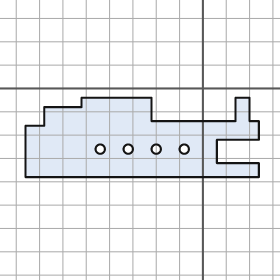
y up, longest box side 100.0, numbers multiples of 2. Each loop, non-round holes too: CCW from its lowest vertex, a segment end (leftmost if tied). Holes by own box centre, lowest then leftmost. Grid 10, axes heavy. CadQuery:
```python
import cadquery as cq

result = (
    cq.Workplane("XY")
    .moveTo(-76.0, -38.0)
    .lineTo(24.0, -38.0)
    .lineTo(24.0, -32.0)
    .lineTo(6.0, -32.0)
    .lineTo(6.0, -22.0)
    .lineTo(24.0, -22.0)
    .lineTo(24.0, -14.0)
    .lineTo(20.0, -14.0)
    .lineTo(20.0, -4.0)
    .lineTo(14.0, -4.0)
    .lineTo(14.0, -14.0)
    .lineTo(-22.0, -14.0)
    .lineTo(-22.0, -4.0)
    .lineTo(-52.0, -4.0)
    .lineTo(-52.0, -8.0)
    .lineTo(-68.0, -8.0)
    .lineTo(-68.0, -16.0)
    .lineTo(-76.0, -16.0)
    .close()
    .moveTo(-44.0, -26.0)
    .circle(2.0)
    .moveTo(-32.0, -26.0)
    .circle(2.0)
    .moveTo(-20.0, -26.0)
    .circle(2.0)
    .moveTo(-8.0, -26.0)
    .circle(2.0)
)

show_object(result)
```